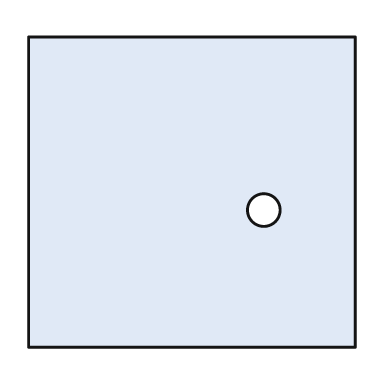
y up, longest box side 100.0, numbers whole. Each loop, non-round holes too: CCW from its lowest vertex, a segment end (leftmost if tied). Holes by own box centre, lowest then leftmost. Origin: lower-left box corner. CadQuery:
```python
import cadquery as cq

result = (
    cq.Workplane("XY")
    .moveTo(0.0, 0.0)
    .lineTo(100.0, 0.0)
    .lineTo(100.0, 95.0)
    .lineTo(0.0, 95.0)
    .close()
    .moveTo(72.0, 42.0)
    .circle(5.0)
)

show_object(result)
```